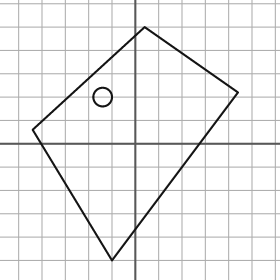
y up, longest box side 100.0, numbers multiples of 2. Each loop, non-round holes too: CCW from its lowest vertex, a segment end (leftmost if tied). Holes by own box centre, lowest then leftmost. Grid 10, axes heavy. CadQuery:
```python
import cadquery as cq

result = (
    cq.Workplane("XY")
    .moveTo(-10.0, -50.0)
    .lineTo(44.0, 22.0)
    .lineTo(4.0, 50.0)
    .lineTo(-44.0, 6.0)
    .close()
    .moveTo(-14.0, 20.0)
    .circle(4.0)
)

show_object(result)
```